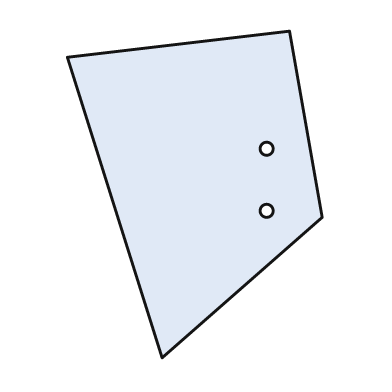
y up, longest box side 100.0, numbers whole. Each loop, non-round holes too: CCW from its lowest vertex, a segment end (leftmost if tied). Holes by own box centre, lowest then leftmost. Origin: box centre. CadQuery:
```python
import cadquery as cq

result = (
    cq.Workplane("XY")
    .moveTo(-10.0, -50.0)
    .lineTo(39.0, -7.0)
    .lineTo(29.0, 50.0)
    .lineTo(-39.0, 42.0)
    .close()
    .moveTo(22.0, -5.0)
    .circle(2.0)
    .moveTo(22.0, 14.0)
    .circle(2.0)
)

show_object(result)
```